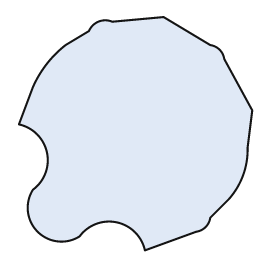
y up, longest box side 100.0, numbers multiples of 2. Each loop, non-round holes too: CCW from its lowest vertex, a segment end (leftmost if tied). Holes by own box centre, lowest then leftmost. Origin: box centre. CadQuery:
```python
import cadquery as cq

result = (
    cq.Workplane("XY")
    .moveTo(4.0, -50.0)
    .lineTo(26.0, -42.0)
    .threePointArc((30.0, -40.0), (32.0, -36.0))
    .lineTo(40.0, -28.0)
    .threePointArc((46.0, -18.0), (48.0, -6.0))
    .lineTo(50.0, 10.0)
    .lineTo(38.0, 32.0)
    .threePointArc((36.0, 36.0), (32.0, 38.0))
    .lineTo(12.0, 50.0)
    .lineTo(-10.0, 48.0)
    .threePointArc((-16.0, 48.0), (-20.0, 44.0))
    .lineTo(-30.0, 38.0)
    .threePointArc((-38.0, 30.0), (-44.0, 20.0))
    .lineTo(-50.0, 4.0)
    .threePointArc((-38.0, -8.0), (-44.0, -24.0))
    .threePointArc((-42.0, -42.0), (-24.0, -44.0))
    .threePointArc((-8.0, -38.0), (4.0, -50.0))
    .close()
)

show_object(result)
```